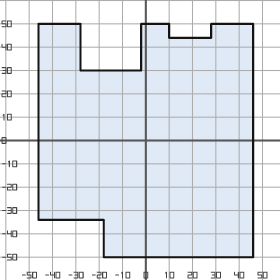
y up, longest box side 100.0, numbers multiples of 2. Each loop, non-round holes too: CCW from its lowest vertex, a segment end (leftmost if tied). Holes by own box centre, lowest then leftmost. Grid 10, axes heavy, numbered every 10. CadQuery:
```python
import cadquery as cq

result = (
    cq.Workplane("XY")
    .moveTo(-18.0, -50.0)
    .lineTo(46.0, -50.0)
    .lineTo(46.0, 50.0)
    .lineTo(28.0, 50.0)
    .lineTo(28.0, 44.0)
    .lineTo(10.0, 44.0)
    .lineTo(10.0, 50.0)
    .lineTo(-2.0, 50.0)
    .lineTo(-2.0, 30.0)
    .lineTo(-28.0, 30.0)
    .lineTo(-28.0, 50.0)
    .lineTo(-46.0, 50.0)
    .lineTo(-46.0, -34.0)
    .lineTo(-18.0, -34.0)
    .close()
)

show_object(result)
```